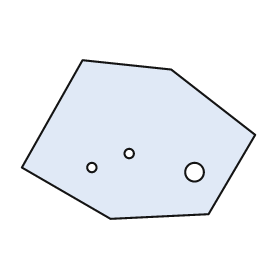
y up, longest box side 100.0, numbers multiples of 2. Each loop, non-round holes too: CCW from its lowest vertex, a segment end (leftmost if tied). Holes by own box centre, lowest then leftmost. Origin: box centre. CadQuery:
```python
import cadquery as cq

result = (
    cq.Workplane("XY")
    .moveTo(-12.0, -34.0)
    .lineTo(30.0, -32.0)
    .lineTo(50.0, 2.0)
    .lineTo(14.0, 30.0)
    .lineTo(-24.0, 34.0)
    .lineTo(-50.0, -12.0)
    .close()
    .moveTo(24.0, -14.0)
    .circle(4.0)
    .moveTo(-20.0, -12.0)
    .circle(2.0)
    .moveTo(-4.0, -6.0)
    .circle(2.0)
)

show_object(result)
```